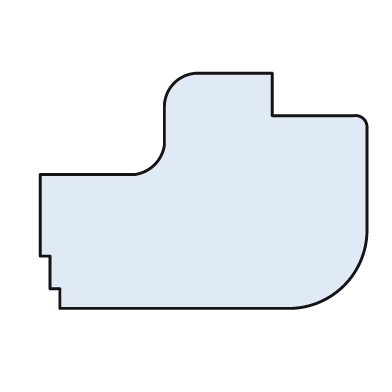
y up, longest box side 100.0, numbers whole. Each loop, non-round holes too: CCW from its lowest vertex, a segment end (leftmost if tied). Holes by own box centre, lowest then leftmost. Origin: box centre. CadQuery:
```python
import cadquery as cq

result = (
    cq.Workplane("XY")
    .moveTo(-44.0, -36.0)
    .lineTo(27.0, -36.0)
    .threePointArc((43.0, -29.0), (50.0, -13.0))
    .lineTo(50.0, 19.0)
    .threePointArc((49.0, 22.0), (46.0, 23.0))
    .lineTo(21.0, 23.0)
    .lineTo(21.0, 36.0)
    .lineTo(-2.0, 36.0)
    .threePointArc((-9.0, 33.0), (-12.0, 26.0))
    .lineTo(-12.0, 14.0)
    .threePointArc((-15.0, 8.0), (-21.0, 5.0))
    .lineTo(-50.0, 5.0)
    .lineTo(-50.0, -20.0)
    .lineTo(-47.0, -20.0)
    .lineTo(-47.0, -30.0)
    .lineTo(-44.0, -30.0)
    .close()
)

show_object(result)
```